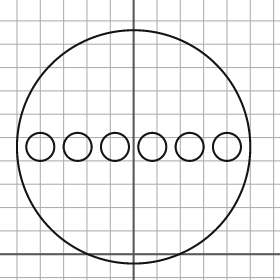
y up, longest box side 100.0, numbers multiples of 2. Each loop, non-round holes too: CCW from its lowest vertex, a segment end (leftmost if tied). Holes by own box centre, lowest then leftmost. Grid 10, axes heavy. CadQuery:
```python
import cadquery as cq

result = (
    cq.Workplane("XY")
    .moveTo(0.0, 46.0)
    .circle(50.0)
    .moveTo(-40.0, 46.0)
    .circle(6.0)
    .moveTo(-24.0, 46.0)
    .circle(6.0)
    .moveTo(-8.0, 46.0)
    .circle(6.0)
    .moveTo(8.0, 46.0)
    .circle(6.0)
    .moveTo(24.0, 46.0)
    .circle(6.0)
    .moveTo(40.0, 46.0)
    .circle(6.0)
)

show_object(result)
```